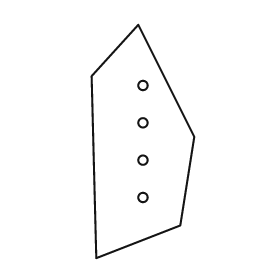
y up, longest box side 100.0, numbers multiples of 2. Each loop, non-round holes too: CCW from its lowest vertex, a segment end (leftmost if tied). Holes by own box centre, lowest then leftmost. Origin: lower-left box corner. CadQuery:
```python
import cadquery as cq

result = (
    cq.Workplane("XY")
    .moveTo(2.0, 0.0)
    .lineTo(38.0, 14.0)
    .lineTo(44.0, 52.0)
    .lineTo(20.0, 100.0)
    .lineTo(0.0, 78.0)
    .close()
    .moveTo(22.0, 26.0)
    .circle(2.0)
    .moveTo(22.0, 42.0)
    .circle(2.0)
    .moveTo(22.0, 58.0)
    .circle(2.0)
    .moveTo(22.0, 74.0)
    .circle(2.0)
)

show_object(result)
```